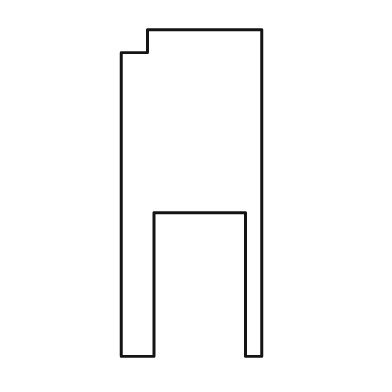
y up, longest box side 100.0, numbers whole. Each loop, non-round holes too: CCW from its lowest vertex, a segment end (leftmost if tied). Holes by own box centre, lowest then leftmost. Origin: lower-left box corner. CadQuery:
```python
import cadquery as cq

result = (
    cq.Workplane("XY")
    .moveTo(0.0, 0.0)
    .lineTo(10.0, 0.0)
    .lineTo(10.0, 44.0)
    .lineTo(38.0, 44.0)
    .lineTo(38.0, 0.0)
    .lineTo(43.0, 0.0)
    .lineTo(43.0, 100.0)
    .lineTo(8.0, 100.0)
    .lineTo(8.0, 93.0)
    .lineTo(0.0, 93.0)
    .close()
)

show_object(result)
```